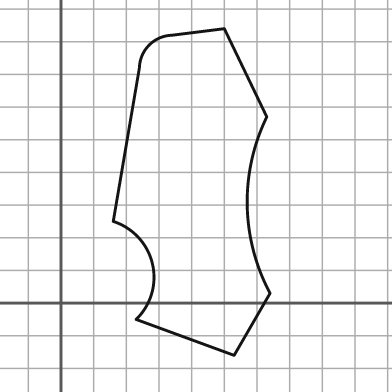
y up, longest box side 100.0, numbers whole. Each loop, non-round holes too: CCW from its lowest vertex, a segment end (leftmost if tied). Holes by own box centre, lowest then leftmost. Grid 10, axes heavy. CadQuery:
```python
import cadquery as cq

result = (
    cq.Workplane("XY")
    .moveTo(53.0, -16.0)
    .lineTo(64.0, 3.0)
    .threePointArc((57.0, 30.0), (63.0, 57.0))
    .lineTo(50.0, 84.0)
    .lineTo(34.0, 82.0)
    .threePointArc((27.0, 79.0), (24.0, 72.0))
    .lineTo(16.0, 25.0)
    .threePointArc((28.0, 12.0), (23.0, -5.0))
    .close()
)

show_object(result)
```